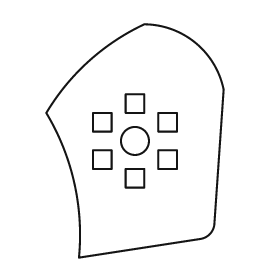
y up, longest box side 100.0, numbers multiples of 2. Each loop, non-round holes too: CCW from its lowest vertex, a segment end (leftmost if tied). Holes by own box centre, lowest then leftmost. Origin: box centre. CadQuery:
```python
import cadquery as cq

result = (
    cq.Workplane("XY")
    .moveTo(-24.0, -50.0)
    .lineTo(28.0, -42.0)
    .threePointArc((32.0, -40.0), (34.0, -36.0))
    .lineTo(38.0, 22.0)
    .threePointArc((26.0, 42.0), (4.0, 50.0))
    .threePointArc((-20.0, 34.0), (-38.0, 12.0))
    .threePointArc((-26.0, -18.0), (-24.0, -50.0))
    .close()
    .moveTo(-4.0, -20.0)
    .lineTo(4.0, -20.0)
    .lineTo(4.0, -12.0)
    .lineTo(-4.0, -12.0)
    .close()
    .moveTo(-18.0, -12.0)
    .lineTo(-10.0, -12.0)
    .lineTo(-10.0, -4.0)
    .lineTo(-18.0, -4.0)
    .close()
    .moveTo(10.0, -12.0)
    .lineTo(18.0, -12.0)
    .lineTo(18.0, -4.0)
    .lineTo(10.0, -4.0)
    .close()
    .moveTo(0.0, 0.0)
    .circle(6.0)
    .moveTo(-18.0, 4.0)
    .lineTo(-10.0, 4.0)
    .lineTo(-10.0, 12.0)
    .lineTo(-18.0, 12.0)
    .close()
    .moveTo(10.0, 4.0)
    .lineTo(18.0, 4.0)
    .lineTo(18.0, 12.0)
    .lineTo(10.0, 12.0)
    .close()
    .moveTo(-4.0, 12.0)
    .lineTo(4.0, 12.0)
    .lineTo(4.0, 20.0)
    .lineTo(-4.0, 20.0)
    .close()
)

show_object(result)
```